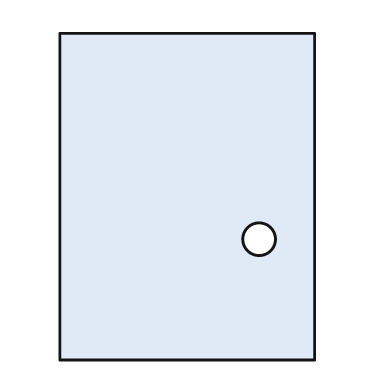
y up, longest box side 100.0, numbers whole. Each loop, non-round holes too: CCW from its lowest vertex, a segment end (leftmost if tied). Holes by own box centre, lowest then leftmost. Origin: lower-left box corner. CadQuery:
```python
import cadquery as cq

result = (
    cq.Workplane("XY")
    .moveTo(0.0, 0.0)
    .lineTo(78.0, 0.0)
    .lineTo(78.0, 100.0)
    .lineTo(0.0, 100.0)
    .close()
    .moveTo(61.0, 37.0)
    .circle(5.0)
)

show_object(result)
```